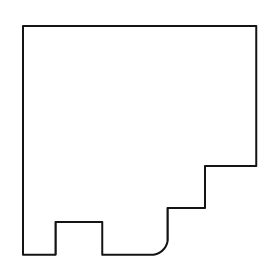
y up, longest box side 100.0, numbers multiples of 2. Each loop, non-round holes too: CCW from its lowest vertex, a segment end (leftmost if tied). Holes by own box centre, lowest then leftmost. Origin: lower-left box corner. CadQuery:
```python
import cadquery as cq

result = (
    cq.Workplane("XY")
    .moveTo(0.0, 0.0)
    .lineTo(14.0, 0.0)
    .lineTo(14.0, 14.0)
    .lineTo(34.0, 14.0)
    .lineTo(34.0, 0.0)
    .lineTo(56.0, 0.0)
    .threePointArc((60.0, 2.0), (62.0, 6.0))
    .lineTo(62.0, 20.0)
    .lineTo(78.0, 20.0)
    .lineTo(78.0, 38.0)
    .lineTo(100.0, 38.0)
    .lineTo(100.0, 98.0)
    .lineTo(0.0, 98.0)
    .close()
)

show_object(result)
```